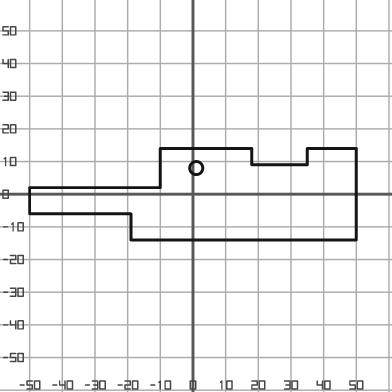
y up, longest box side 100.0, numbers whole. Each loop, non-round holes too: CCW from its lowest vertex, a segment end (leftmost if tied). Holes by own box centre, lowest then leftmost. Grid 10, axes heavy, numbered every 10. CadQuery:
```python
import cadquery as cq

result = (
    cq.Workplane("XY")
    .moveTo(-19.0, -14.0)
    .lineTo(50.0, -14.0)
    .lineTo(50.0, 14.0)
    .lineTo(35.0, 14.0)
    .lineTo(35.0, 9.0)
    .lineTo(18.0, 9.0)
    .lineTo(18.0, 14.0)
    .lineTo(-10.0, 14.0)
    .lineTo(-10.0, 2.0)
    .lineTo(-50.0, 2.0)
    .lineTo(-50.0, -6.0)
    .lineTo(-19.0, -6.0)
    .close()
    .moveTo(1.0, 8.0)
    .circle(2.0)
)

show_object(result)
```